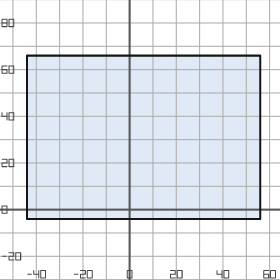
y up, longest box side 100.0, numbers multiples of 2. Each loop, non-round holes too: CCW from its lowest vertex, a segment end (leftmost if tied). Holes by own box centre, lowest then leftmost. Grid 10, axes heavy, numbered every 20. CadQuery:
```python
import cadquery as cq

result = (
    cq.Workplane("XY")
    .moveTo(-44.0, -4.0)
    .lineTo(56.0, -4.0)
    .lineTo(56.0, 66.0)
    .lineTo(-44.0, 66.0)
    .close()
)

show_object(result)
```